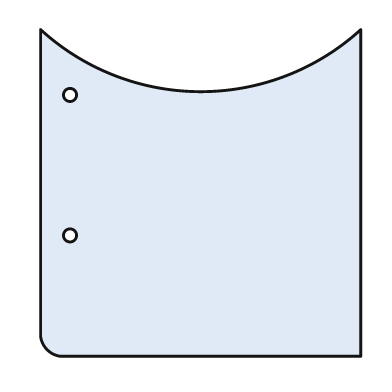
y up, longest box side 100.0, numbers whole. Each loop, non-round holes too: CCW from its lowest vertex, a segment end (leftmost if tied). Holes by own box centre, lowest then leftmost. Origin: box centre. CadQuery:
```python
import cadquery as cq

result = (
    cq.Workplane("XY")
    .moveTo(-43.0, -50.0)
    .lineTo(49.0, -50.0)
    .lineTo(49.0, 50.0)
    .threePointArc((0.0, 31.0), (-49.0, 50.0))
    .lineTo(-49.0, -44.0)
    .threePointArc((-47.0, -48.0), (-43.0, -50.0))
    .close()
    .moveTo(-40.0, -13.0)
    .circle(2.0)
    .moveTo(-40.0, 30.0)
    .circle(2.0)
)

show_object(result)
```